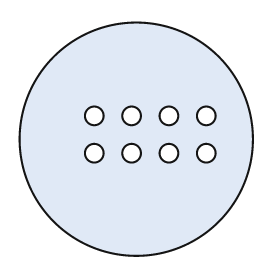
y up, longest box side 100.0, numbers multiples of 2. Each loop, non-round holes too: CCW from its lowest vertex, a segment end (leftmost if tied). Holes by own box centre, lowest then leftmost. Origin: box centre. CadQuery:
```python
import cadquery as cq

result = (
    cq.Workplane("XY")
    .moveTo(0.0, 0.0)
    .circle(50.0)
    .moveTo(-18.0, -6.0)
    .circle(4.0)
    .moveTo(-2.0, -6.0)
    .circle(4.0)
    .moveTo(14.0, -6.0)
    .circle(4.0)
    .moveTo(30.0, -6.0)
    .circle(4.0)
    .moveTo(-18.0, 10.0)
    .circle(4.0)
    .moveTo(-2.0, 10.0)
    .circle(4.0)
    .moveTo(14.0, 10.0)
    .circle(4.0)
    .moveTo(30.0, 10.0)
    .circle(4.0)
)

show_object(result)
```